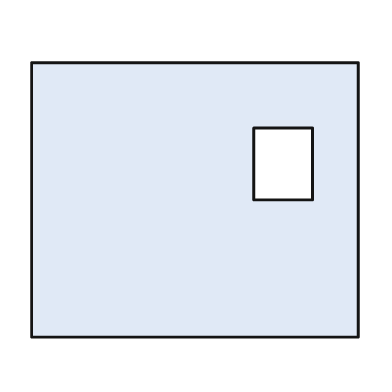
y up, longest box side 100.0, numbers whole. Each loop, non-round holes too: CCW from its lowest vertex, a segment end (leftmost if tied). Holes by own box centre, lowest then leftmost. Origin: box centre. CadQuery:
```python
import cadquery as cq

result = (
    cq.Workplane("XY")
    .moveTo(-50.0, -42.0)
    .lineTo(50.0, -42.0)
    .lineTo(50.0, 42.0)
    .lineTo(-50.0, 42.0)
    .close()
    .moveTo(18.0, 0.0)
    .lineTo(36.0, 0.0)
    .lineTo(36.0, 22.0)
    .lineTo(18.0, 22.0)
    .close()
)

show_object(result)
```